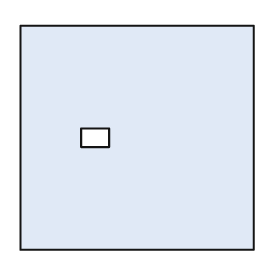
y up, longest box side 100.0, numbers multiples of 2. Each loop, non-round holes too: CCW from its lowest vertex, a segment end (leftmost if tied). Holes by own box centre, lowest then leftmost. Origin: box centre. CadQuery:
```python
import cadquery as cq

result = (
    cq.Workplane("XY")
    .moveTo(-50.0, -48.0)
    .lineTo(50.0, -48.0)
    .lineTo(50.0, 48.0)
    .lineTo(-50.0, 48.0)
    .close()
    .moveTo(-24.0, -4.0)
    .lineTo(-12.0, -4.0)
    .lineTo(-12.0, 4.0)
    .lineTo(-24.0, 4.0)
    .close()
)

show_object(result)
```